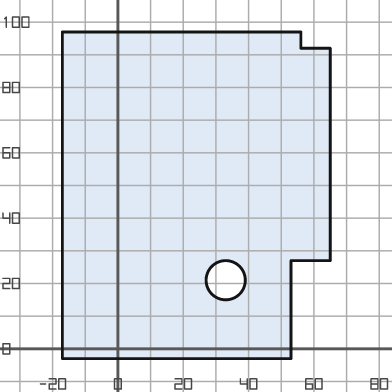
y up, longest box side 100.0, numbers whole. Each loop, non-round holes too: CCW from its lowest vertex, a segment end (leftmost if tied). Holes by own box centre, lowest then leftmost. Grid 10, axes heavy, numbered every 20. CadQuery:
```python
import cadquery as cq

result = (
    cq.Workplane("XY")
    .moveTo(-17.0, -3.0)
    .lineTo(53.0, -3.0)
    .lineTo(53.0, 27.0)
    .lineTo(65.0, 27.0)
    .lineTo(65.0, 92.0)
    .lineTo(56.0, 92.0)
    .lineTo(56.0, 97.0)
    .lineTo(-17.0, 97.0)
    .close()
    .moveTo(33.0, 21.0)
    .circle(6.0)
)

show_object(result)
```